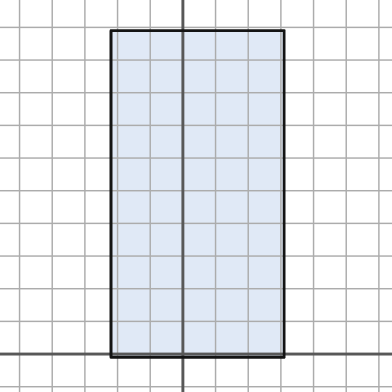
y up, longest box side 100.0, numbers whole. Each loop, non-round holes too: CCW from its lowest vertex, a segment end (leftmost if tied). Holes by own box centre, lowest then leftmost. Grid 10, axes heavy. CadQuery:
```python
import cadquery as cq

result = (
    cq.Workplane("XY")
    .moveTo(-22.0, -1.0)
    .lineTo(31.0, -1.0)
    .lineTo(31.0, 99.0)
    .lineTo(-22.0, 99.0)
    .close()
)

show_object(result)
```